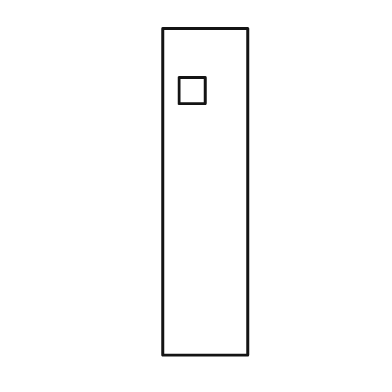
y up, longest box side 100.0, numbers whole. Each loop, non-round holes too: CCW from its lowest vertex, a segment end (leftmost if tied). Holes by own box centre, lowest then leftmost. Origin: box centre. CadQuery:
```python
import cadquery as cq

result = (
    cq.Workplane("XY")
    .moveTo(-13.0, -50.0)
    .lineTo(13.0, -50.0)
    .lineTo(13.0, 50.0)
    .lineTo(-13.0, 50.0)
    .close()
    .moveTo(-8.0, 27.0)
    .lineTo(0.0, 27.0)
    .lineTo(0.0, 35.0)
    .lineTo(-8.0, 35.0)
    .close()
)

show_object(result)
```